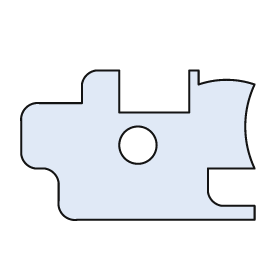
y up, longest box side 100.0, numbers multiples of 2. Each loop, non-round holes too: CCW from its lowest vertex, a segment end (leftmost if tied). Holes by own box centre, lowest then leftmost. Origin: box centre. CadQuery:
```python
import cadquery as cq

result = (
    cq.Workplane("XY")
    .moveTo(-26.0, -32.0)
    .lineTo(50.0, -32.0)
    .lineTo(50.0, -26.0)
    .lineTo(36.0, -26.0)
    .threePointArc((32.0, -24.0), (30.0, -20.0))
    .lineTo(30.0, -10.0)
    .lineTo(50.0, -10.0)
    .threePointArc((46.0, 8.0), (50.0, 26.0))
    .threePointArc((38.0, 28.0), (26.0, 26.0))
    .lineTo(26.0, 32.0)
    .lineTo(22.0, 32.0)
    .lineTo(22.0, 14.0)
    .lineTo(-8.0, 14.0)
    .lineTo(-8.0, 32.0)
    .lineTo(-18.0, 32.0)
    .threePointArc((-22.0, 30.0), (-24.0, 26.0))
    .lineTo(-24.0, 18.0)
    .lineTo(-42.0, 18.0)
    .threePointArc((-48.0, 16.0), (-50.0, 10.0))
    .lineTo(-50.0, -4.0)
    .threePointArc((-48.0, -8.0), (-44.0, -10.0))
    .lineTo(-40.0, -10.0)
    .threePointArc((-36.0, -12.0), (-34.0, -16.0))
    .lineTo(-34.0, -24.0)
    .threePointArc((-32.0, -30.0), (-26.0, -32.0))
    .close()
    .moveTo(0.0, 0.0)
    .circle(8.0)
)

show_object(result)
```